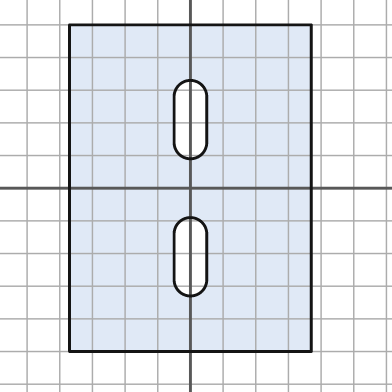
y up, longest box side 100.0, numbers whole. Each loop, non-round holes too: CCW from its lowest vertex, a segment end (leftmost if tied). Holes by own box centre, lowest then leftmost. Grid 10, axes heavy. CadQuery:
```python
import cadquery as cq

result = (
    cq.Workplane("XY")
    .moveTo(-37.0, -50.0)
    .lineTo(37.0, -50.0)
    .lineTo(37.0, 50.0)
    .lineTo(-37.0, 50.0)
    .close()
    .moveTo(-5.0, -28.0)
    .threePointArc((0.0, -33.0), (5.0, -28.0))
    .lineTo(5.0, -14.0)
    .threePointArc((0.0, -9.0), (-5.0, -14.0))
    .close()
    .moveTo(-5.0, 14.0)
    .threePointArc((0.0, 9.0), (5.0, 14.0))
    .lineTo(5.0, 28.0)
    .threePointArc((0.0, 33.0), (-5.0, 28.0))
    .close()
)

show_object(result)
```